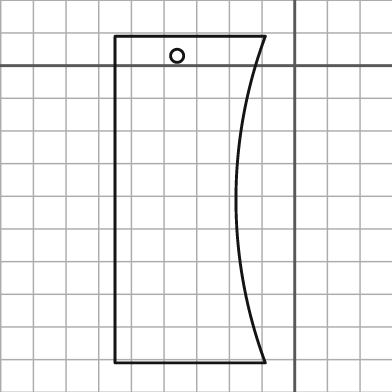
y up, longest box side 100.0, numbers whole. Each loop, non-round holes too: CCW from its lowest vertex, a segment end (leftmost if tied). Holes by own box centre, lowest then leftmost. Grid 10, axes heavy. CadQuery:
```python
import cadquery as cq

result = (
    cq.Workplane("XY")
    .moveTo(-55.0, -91.0)
    .lineTo(-9.0, -91.0)
    .threePointArc((-18.0, -41.0), (-9.0, 9.0))
    .lineTo(-55.0, 9.0)
    .close()
    .moveTo(-36.0, 3.0)
    .circle(2.0)
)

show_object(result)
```